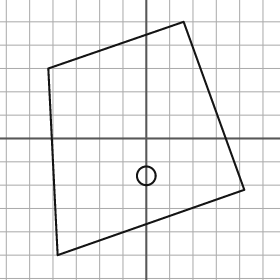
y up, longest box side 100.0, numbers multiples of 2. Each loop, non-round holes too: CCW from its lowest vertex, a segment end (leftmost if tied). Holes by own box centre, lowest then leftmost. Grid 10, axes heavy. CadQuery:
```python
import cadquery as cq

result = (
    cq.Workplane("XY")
    .moveTo(-38.0, -50.0)
    .lineTo(42.0, -22.0)
    .lineTo(16.0, 50.0)
    .lineTo(-42.0, 30.0)
    .close()
    .moveTo(0.0, -16.0)
    .circle(4.0)
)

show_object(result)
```